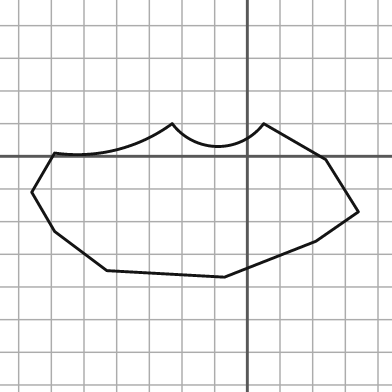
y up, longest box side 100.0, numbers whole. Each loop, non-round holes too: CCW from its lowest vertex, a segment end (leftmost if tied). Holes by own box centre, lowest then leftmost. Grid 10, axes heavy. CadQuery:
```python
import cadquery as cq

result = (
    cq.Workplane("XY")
    .moveTo(-7.0, -37.0)
    .lineTo(21.0, -26.0)
    .lineTo(34.0, -17.0)
    .lineTo(24.0, -1.0)
    .lineTo(5.0, 10.0)
    .threePointArc((-9.0, 3.0), (-23.0, 10.0))
    .threePointArc((-40.0, 2.0), (-59.0, 1.0))
    .lineTo(-66.0, -11.0)
    .lineTo(-59.0, -23.0)
    .lineTo(-43.0, -35.0)
    .close()
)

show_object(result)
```